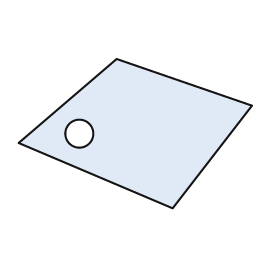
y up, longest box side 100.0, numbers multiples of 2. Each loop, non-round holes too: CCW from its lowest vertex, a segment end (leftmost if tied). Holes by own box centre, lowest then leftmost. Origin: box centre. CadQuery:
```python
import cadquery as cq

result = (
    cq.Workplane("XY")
    .moveTo(16.0, -32.0)
    .lineTo(50.0, 12.0)
    .lineTo(-8.0, 32.0)
    .lineTo(-50.0, -4.0)
    .close()
    .moveTo(-24.0, 0.0)
    .circle(6.0)
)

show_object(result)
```